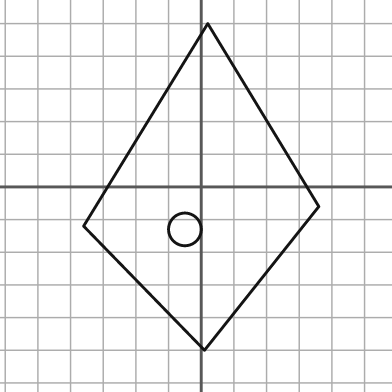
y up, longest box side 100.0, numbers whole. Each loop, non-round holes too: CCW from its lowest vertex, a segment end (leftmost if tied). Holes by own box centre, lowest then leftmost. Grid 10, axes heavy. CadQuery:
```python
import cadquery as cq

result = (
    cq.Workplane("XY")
    .moveTo(1.0, -50.0)
    .lineTo(36.0, -6.0)
    .lineTo(2.0, 50.0)
    .lineTo(-36.0, -12.0)
    .close()
    .moveTo(-5.0, -13.0)
    .circle(5.0)
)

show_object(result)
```